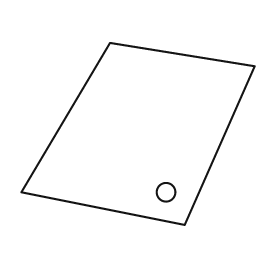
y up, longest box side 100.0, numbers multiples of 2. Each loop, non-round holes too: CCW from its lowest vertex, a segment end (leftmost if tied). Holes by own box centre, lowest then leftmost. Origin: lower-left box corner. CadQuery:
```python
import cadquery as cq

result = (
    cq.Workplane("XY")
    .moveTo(70.0, 0.0)
    .lineTo(100.0, 68.0)
    .lineTo(38.0, 78.0)
    .lineTo(0.0, 14.0)
    .close()
    .moveTo(62.0, 14.0)
    .circle(4.0)
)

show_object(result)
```